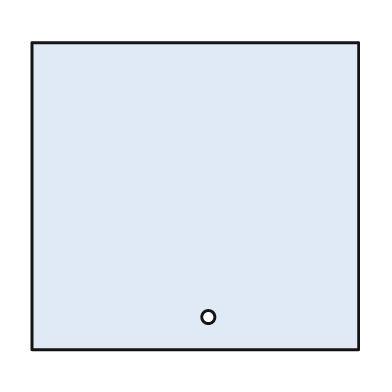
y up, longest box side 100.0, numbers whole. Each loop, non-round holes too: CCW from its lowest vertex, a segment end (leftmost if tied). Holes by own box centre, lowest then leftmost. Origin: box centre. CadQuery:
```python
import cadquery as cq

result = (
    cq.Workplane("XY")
    .moveTo(-50.0, -47.0)
    .lineTo(50.0, -47.0)
    .lineTo(50.0, 47.0)
    .lineTo(-50.0, 47.0)
    .close()
    .moveTo(4.0, -37.0)
    .circle(2.0)
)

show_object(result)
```